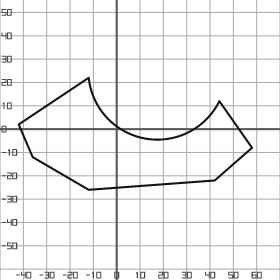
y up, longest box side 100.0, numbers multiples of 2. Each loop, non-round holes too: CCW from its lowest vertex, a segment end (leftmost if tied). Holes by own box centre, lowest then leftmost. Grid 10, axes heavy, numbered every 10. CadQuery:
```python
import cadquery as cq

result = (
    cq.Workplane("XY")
    .moveTo(-12.0, -26.0)
    .lineTo(42.0, -22.0)
    .lineTo(58.0, -8.0)
    .lineTo(44.0, 12.0)
    .threePointArc((12.0, -4.0), (-12.0, 22.0))
    .lineTo(-42.0, 2.0)
    .lineTo(-36.0, -12.0)
    .close()
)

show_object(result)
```